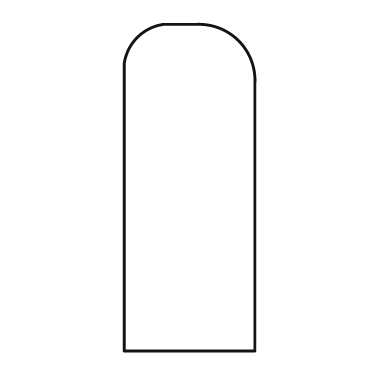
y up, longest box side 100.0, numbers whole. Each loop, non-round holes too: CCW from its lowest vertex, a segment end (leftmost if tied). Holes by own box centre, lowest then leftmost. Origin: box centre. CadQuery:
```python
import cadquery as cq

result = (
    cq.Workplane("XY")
    .moveTo(-20.0, -50.0)
    .lineTo(20.0, -50.0)
    .lineTo(20.0, 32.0)
    .threePointArc((15.0, 45.0), (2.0, 50.0))
    .lineTo(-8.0, 50.0)
    .threePointArc((-16.0, 46.0), (-20.0, 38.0))
    .close()
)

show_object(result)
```